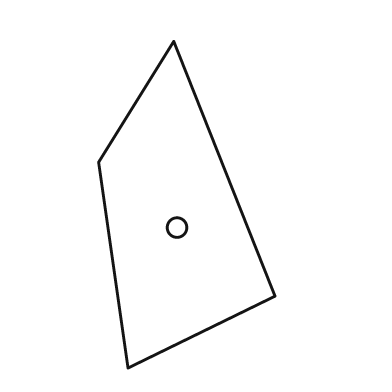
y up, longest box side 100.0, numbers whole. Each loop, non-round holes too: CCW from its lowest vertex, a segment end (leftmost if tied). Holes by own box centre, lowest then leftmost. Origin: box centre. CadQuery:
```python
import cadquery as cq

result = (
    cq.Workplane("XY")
    .moveTo(-18.0, -50.0)
    .lineTo(27.0, -28.0)
    .lineTo(-4.0, 50.0)
    .lineTo(-27.0, 13.0)
    .close()
    .moveTo(-3.0, -7.0)
    .circle(3.0)
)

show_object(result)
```